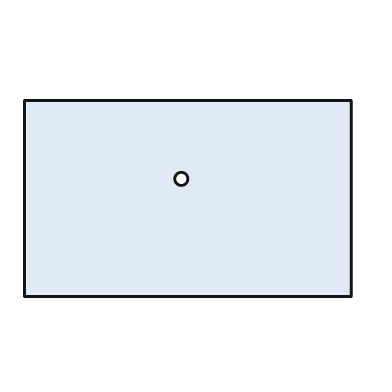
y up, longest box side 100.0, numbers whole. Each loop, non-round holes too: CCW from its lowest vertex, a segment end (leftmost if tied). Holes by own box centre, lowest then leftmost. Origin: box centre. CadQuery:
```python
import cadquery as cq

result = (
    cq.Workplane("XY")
    .moveTo(-50.0, -30.0)
    .lineTo(50.0, -30.0)
    .lineTo(50.0, 30.0)
    .lineTo(-50.0, 30.0)
    .close()
    .moveTo(-2.0, 6.0)
    .circle(2.0)
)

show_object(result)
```